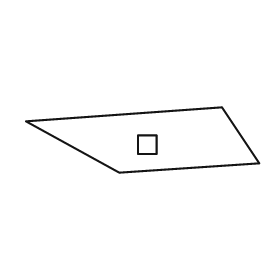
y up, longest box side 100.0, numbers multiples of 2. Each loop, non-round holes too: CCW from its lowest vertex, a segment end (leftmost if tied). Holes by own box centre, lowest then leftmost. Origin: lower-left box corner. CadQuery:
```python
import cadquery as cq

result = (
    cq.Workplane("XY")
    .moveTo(40.0, 0.0)
    .lineTo(100.0, 4.0)
    .lineTo(84.0, 28.0)
    .lineTo(0.0, 22.0)
    .close()
    .moveTo(48.0, 8.0)
    .lineTo(56.0, 8.0)
    .lineTo(56.0, 16.0)
    .lineTo(48.0, 16.0)
    .close()
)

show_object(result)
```